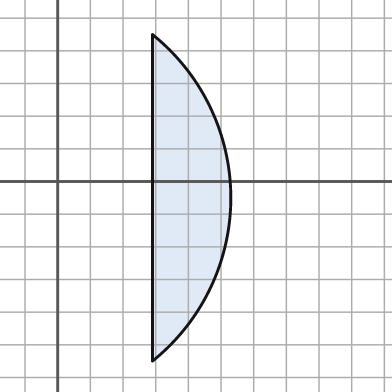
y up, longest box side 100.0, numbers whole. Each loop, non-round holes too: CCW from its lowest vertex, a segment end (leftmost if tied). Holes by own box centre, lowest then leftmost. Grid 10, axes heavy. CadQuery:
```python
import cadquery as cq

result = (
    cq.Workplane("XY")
    .moveTo(29.0, -55.0)
    .threePointArc((53.0, -5.0), (29.0, 45.0))
    .close()
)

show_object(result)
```